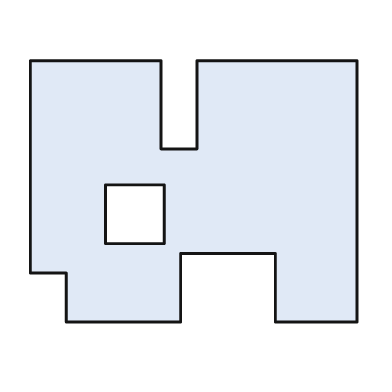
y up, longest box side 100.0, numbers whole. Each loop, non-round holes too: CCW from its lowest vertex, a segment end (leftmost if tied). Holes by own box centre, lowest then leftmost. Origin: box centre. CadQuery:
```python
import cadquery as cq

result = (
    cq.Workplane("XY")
    .moveTo(-39.0, -40.0)
    .lineTo(-4.0, -40.0)
    .lineTo(-4.0, -19.0)
    .lineTo(25.0, -19.0)
    .lineTo(25.0, -40.0)
    .lineTo(50.0, -40.0)
    .lineTo(50.0, 40.0)
    .lineTo(1.0, 40.0)
    .lineTo(1.0, 13.0)
    .lineTo(-10.0, 13.0)
    .lineTo(-10.0, 40.0)
    .lineTo(-50.0, 40.0)
    .lineTo(-50.0, -25.0)
    .lineTo(-39.0, -25.0)
    .close()
    .moveTo(-27.0, -16.0)
    .lineTo(-9.0, -16.0)
    .lineTo(-9.0, 2.0)
    .lineTo(-27.0, 2.0)
    .close()
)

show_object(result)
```